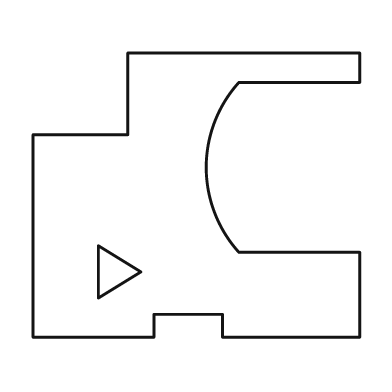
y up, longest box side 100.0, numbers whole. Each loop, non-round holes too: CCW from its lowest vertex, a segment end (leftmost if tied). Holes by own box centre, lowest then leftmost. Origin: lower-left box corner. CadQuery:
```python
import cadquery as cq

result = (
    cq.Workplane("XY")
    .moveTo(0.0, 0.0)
    .lineTo(37.0, 0.0)
    .lineTo(37.0, 7.0)
    .lineTo(58.0, 7.0)
    .lineTo(58.0, 0.0)
    .lineTo(100.0, 0.0)
    .lineTo(100.0, 26.0)
    .lineTo(63.0, 26.0)
    .threePointArc((53.0, 52.0), (63.0, 78.0))
    .lineTo(100.0, 78.0)
    .lineTo(100.0, 87.0)
    .lineTo(29.0, 87.0)
    .lineTo(29.0, 62.0)
    .lineTo(0.0, 62.0)
    .close()
    .moveTo(20.0, 12.0)
    .lineTo(33.0, 20.0)
    .lineTo(20.0, 28.0)
    .close()
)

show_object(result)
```